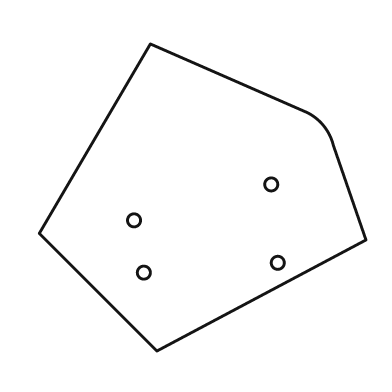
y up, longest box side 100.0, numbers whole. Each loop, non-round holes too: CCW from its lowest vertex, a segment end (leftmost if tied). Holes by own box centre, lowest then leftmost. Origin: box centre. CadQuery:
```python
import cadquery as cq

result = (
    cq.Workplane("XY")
    .moveTo(-14.0, -47.0)
    .lineTo(50.0, -13.0)
    .lineTo(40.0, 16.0)
    .threePointArc((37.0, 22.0), (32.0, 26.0))
    .lineTo(-16.0, 47.0)
    .lineTo(-50.0, -11.0)
    .close()
    .moveTo(-18.0, -23.0)
    .circle(2.0)
    .moveTo(23.0, -20.0)
    .circle(2.0)
    .moveTo(-21.0, -7.0)
    .circle(2.0)
    .moveTo(21.0, 4.0)
    .circle(2.0)
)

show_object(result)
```